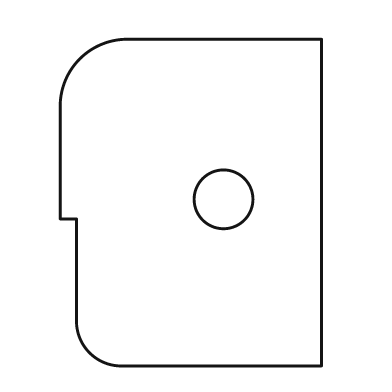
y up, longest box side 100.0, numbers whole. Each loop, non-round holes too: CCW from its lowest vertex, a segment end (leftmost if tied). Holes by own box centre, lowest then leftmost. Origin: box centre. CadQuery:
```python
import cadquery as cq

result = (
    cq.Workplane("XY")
    .moveTo(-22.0, -50.0)
    .lineTo(40.0, -50.0)
    .lineTo(40.0, 50.0)
    .lineTo(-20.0, 50.0)
    .threePointArc((-34.0, 44.0), (-40.0, 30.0))
    .lineTo(-40.0, -5.0)
    .lineTo(-35.0, -5.0)
    .lineTo(-35.0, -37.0)
    .threePointArc((-31.0, -46.0), (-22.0, -50.0))
    .close()
    .moveTo(10.0, 1.0)
    .circle(9.0)
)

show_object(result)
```